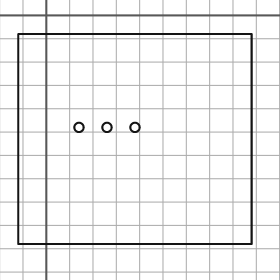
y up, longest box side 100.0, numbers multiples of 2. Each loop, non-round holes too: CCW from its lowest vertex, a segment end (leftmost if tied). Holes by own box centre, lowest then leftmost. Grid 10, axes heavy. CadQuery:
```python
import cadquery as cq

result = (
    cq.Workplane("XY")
    .moveTo(-12.0, -98.0)
    .lineTo(88.0, -98.0)
    .lineTo(88.0, -8.0)
    .lineTo(-12.0, -8.0)
    .close()
    .moveTo(14.0, -48.0)
    .circle(2.0)
    .moveTo(26.0, -48.0)
    .circle(2.0)
    .moveTo(38.0, -48.0)
    .circle(2.0)
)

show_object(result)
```